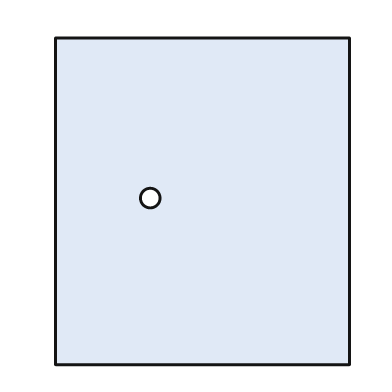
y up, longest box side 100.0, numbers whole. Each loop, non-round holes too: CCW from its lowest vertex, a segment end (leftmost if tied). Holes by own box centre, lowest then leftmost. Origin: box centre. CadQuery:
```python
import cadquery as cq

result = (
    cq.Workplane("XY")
    .moveTo(-45.0, -50.0)
    .lineTo(45.0, -50.0)
    .lineTo(45.0, 50.0)
    .lineTo(-45.0, 50.0)
    .close()
    .moveTo(-16.0, 1.0)
    .circle(3.0)
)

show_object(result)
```